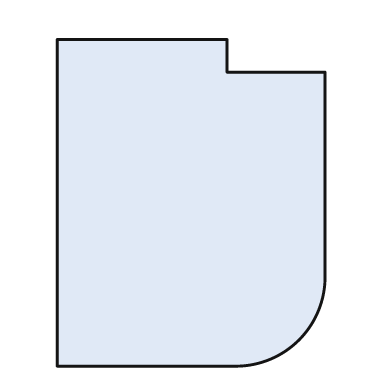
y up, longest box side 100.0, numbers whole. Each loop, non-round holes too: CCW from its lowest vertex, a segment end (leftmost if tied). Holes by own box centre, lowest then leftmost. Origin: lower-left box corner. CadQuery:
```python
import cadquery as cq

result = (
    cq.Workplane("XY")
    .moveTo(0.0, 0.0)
    .lineTo(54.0, 0.0)
    .threePointArc((74.0, 8.0), (82.0, 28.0))
    .lineTo(82.0, 90.0)
    .lineTo(52.0, 90.0)
    .lineTo(52.0, 100.0)
    .lineTo(0.0, 100.0)
    .close()
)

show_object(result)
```